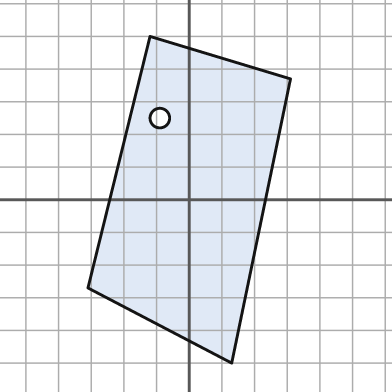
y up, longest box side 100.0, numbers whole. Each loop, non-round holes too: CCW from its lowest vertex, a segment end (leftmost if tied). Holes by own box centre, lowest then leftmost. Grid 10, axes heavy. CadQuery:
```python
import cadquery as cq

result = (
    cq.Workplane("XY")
    .moveTo(13.0, -50.0)
    .lineTo(31.0, 37.0)
    .lineTo(-12.0, 50.0)
    .lineTo(-31.0, -27.0)
    .close()
    .moveTo(-9.0, 25.0)
    .circle(3.0)
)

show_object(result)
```